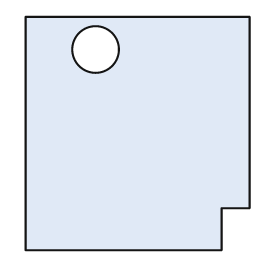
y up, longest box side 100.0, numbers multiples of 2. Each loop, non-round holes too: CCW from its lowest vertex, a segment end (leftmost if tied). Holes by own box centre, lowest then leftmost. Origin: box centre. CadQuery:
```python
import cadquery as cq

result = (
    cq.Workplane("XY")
    .moveTo(-48.0, -50.0)
    .lineTo(36.0, -50.0)
    .lineTo(36.0, -32.0)
    .lineTo(48.0, -32.0)
    .lineTo(48.0, 50.0)
    .lineTo(-48.0, 50.0)
    .close()
    .moveTo(-18.0, 36.0)
    .circle(10.0)
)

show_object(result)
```